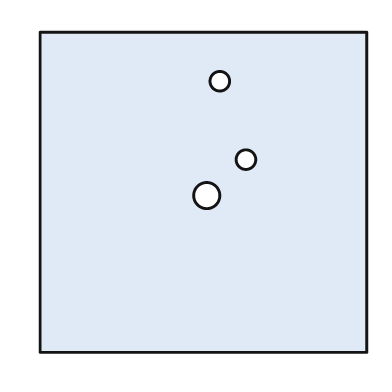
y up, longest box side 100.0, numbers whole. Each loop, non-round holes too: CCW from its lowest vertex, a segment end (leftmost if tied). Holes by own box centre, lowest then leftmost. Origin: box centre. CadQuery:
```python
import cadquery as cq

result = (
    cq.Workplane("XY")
    .moveTo(-50.0, -49.0)
    .lineTo(50.0, -49.0)
    .lineTo(50.0, 49.0)
    .lineTo(-50.0, 49.0)
    .close()
    .moveTo(1.0, -1.0)
    .circle(4.0)
    .moveTo(13.0, 10.0)
    .circle(3.0)
    .moveTo(5.0, 34.0)
    .circle(3.0)
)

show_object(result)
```